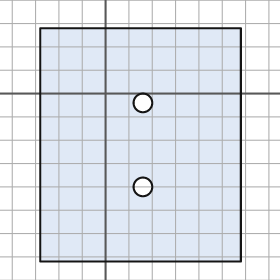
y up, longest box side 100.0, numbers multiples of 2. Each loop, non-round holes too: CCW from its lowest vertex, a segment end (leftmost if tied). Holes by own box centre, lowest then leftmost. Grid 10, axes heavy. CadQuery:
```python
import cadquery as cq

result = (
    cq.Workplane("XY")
    .moveTo(-28.0, -72.0)
    .lineTo(58.0, -72.0)
    .lineTo(58.0, 28.0)
    .lineTo(-28.0, 28.0)
    .close()
    .moveTo(16.0, -40.0)
    .circle(4.0)
    .moveTo(16.0, -4.0)
    .circle(4.0)
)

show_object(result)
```